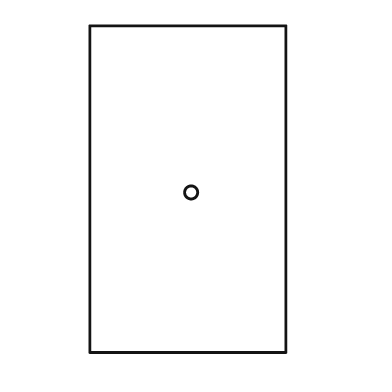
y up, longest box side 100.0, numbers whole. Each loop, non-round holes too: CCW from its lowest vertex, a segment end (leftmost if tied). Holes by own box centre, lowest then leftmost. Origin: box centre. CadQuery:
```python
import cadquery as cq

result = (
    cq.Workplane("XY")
    .moveTo(-30.0, -50.0)
    .lineTo(30.0, -50.0)
    .lineTo(30.0, 50.0)
    .lineTo(-30.0, 50.0)
    .close()
    .moveTo(1.0, -1.0)
    .circle(2.0)
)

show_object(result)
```